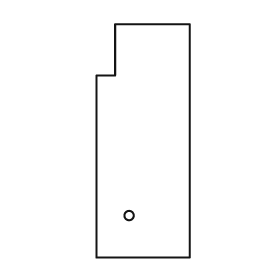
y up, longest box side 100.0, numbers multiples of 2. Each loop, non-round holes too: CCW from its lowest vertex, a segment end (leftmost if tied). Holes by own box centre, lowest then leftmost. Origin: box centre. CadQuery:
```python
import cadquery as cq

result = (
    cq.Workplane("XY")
    .moveTo(-20.0, -50.0)
    .lineTo(20.0, -50.0)
    .lineTo(20.0, 50.0)
    .lineTo(-12.0, 50.0)
    .lineTo(-12.0, 28.0)
    .lineTo(-20.0, 28.0)
    .close()
    .moveTo(-6.0, -32.0)
    .circle(2.0)
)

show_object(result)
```